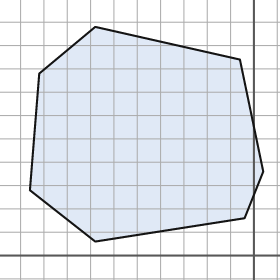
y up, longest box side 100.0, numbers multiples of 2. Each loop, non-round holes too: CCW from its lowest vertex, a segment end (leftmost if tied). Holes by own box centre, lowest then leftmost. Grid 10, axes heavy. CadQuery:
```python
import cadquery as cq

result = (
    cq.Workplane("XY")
    .moveTo(-68.0, 6.0)
    .lineTo(-4.0, 16.0)
    .lineTo(4.0, 36.0)
    .lineTo(-6.0, 84.0)
    .lineTo(-68.0, 98.0)
    .lineTo(-92.0, 78.0)
    .lineTo(-96.0, 28.0)
    .close()
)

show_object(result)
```